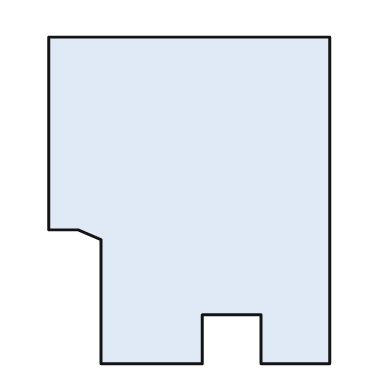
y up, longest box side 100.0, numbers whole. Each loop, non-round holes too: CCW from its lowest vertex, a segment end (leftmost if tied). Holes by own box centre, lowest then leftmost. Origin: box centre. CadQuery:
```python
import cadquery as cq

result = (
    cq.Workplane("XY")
    .moveTo(-27.0, -50.0)
    .lineTo(4.0, -50.0)
    .lineTo(4.0, -35.0)
    .lineTo(22.0, -35.0)
    .lineTo(22.0, -50.0)
    .lineTo(43.0, -50.0)
    .lineTo(43.0, 50.0)
    .lineTo(-43.0, 50.0)
    .lineTo(-43.0, -9.0)
    .lineTo(-34.0, -9.0)
    .lineTo(-27.0, -12.0)
    .close()
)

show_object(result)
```